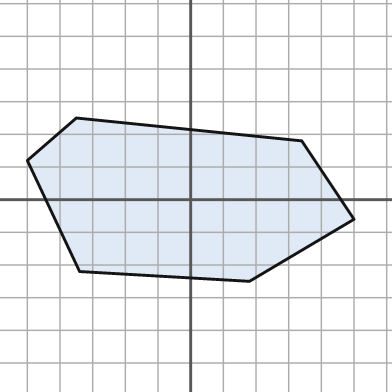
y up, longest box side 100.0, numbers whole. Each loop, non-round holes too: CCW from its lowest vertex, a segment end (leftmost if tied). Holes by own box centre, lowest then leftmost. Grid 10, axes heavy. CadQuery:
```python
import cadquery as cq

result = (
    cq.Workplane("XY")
    .moveTo(18.0, -25.0)
    .lineTo(50.0, -6.0)
    .lineTo(34.0, 18.0)
    .lineTo(-35.0, 25.0)
    .lineTo(-50.0, 12.0)
    .lineTo(-34.0, -22.0)
    .close()
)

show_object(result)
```